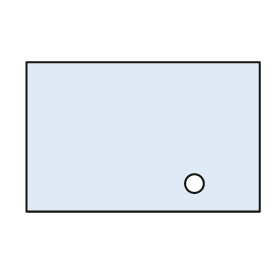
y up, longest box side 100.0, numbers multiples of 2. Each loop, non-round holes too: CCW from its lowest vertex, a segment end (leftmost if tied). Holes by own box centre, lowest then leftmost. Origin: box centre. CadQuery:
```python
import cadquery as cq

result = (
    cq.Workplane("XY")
    .moveTo(-50.0, -32.0)
    .lineTo(50.0, -32.0)
    .lineTo(50.0, 32.0)
    .lineTo(-50.0, 32.0)
    .close()
    .moveTo(22.0, -20.0)
    .circle(4.0)
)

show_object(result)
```